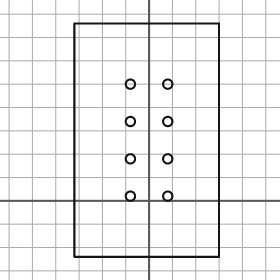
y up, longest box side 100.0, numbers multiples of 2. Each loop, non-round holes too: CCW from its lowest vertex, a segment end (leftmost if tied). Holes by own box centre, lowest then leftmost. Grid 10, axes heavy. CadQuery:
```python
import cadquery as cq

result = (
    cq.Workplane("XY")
    .moveTo(-32.0, -24.0)
    .lineTo(30.0, -24.0)
    .lineTo(30.0, 76.0)
    .lineTo(-32.0, 76.0)
    .close()
    .moveTo(-8.0, 2.0)
    .circle(2.0)
    .moveTo(8.0, 2.0)
    .circle(2.0)
    .moveTo(-8.0, 18.0)
    .circle(2.0)
    .moveTo(8.0, 18.0)
    .circle(2.0)
    .moveTo(-8.0, 34.0)
    .circle(2.0)
    .moveTo(8.0, 34.0)
    .circle(2.0)
    .moveTo(-8.0, 50.0)
    .circle(2.0)
    .moveTo(8.0, 50.0)
    .circle(2.0)
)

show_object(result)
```